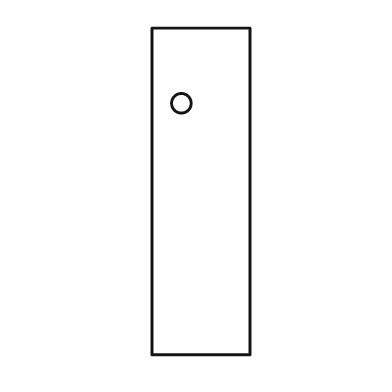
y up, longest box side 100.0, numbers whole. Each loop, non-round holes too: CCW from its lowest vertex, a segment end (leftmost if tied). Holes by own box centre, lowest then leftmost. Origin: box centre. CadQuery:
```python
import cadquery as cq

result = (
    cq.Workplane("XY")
    .moveTo(-15.0, -50.0)
    .lineTo(15.0, -50.0)
    .lineTo(15.0, 50.0)
    .lineTo(-15.0, 50.0)
    .close()
    .moveTo(-6.0, 27.0)
    .circle(3.0)
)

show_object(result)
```